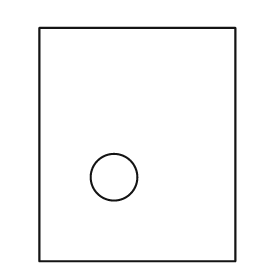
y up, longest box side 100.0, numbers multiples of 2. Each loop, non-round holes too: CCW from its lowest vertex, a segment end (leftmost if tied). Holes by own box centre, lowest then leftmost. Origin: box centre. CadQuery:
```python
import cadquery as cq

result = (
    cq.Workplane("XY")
    .moveTo(-42.0, -50.0)
    .lineTo(42.0, -50.0)
    .lineTo(42.0, 50.0)
    .lineTo(-42.0, 50.0)
    .close()
    .moveTo(-10.0, -14.0)
    .circle(10.0)
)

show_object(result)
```